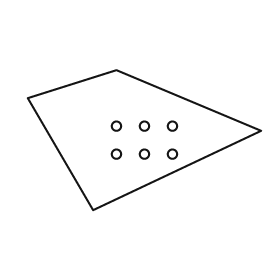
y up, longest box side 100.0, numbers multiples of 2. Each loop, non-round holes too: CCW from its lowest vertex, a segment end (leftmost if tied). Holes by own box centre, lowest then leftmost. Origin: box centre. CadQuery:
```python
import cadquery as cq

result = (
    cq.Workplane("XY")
    .moveTo(-22.0, -30.0)
    .lineTo(50.0, 4.0)
    .lineTo(-12.0, 30.0)
    .lineTo(-50.0, 18.0)
    .close()
    .moveTo(-12.0, -6.0)
    .circle(2.0)
    .moveTo(0.0, -6.0)
    .circle(2.0)
    .moveTo(12.0, -6.0)
    .circle(2.0)
    .moveTo(-12.0, 6.0)
    .circle(2.0)
    .moveTo(0.0, 6.0)
    .circle(2.0)
    .moveTo(12.0, 6.0)
    .circle(2.0)
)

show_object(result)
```